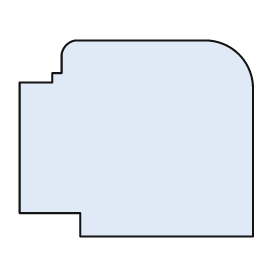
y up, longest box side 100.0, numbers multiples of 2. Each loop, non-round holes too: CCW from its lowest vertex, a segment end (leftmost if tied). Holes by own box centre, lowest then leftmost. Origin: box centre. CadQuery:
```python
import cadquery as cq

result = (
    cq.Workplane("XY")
    .moveTo(-24.0, -42.0)
    .lineTo(50.0, -42.0)
    .lineTo(50.0, 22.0)
    .threePointArc((44.0, 36.0), (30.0, 42.0))
    .lineTo(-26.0, 42.0)
    .threePointArc((-30.0, 40.0), (-32.0, 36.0))
    .lineTo(-32.0, 28.0)
    .lineTo(-36.0, 28.0)
    .lineTo(-36.0, 24.0)
    .lineTo(-50.0, 24.0)
    .lineTo(-50.0, -32.0)
    .lineTo(-24.0, -32.0)
    .close()
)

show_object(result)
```